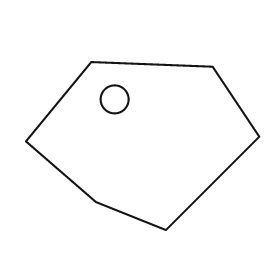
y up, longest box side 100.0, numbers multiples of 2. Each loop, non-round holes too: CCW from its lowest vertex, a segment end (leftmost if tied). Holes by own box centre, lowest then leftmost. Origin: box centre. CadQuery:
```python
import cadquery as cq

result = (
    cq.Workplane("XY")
    .moveTo(10.0, -36.0)
    .lineTo(50.0, 4.0)
    .lineTo(30.0, 34.0)
    .lineTo(-22.0, 36.0)
    .lineTo(-50.0, 2.0)
    .lineTo(-20.0, -24.0)
    .close()
    .moveTo(-12.0, 20.0)
    .circle(6.0)
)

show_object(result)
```